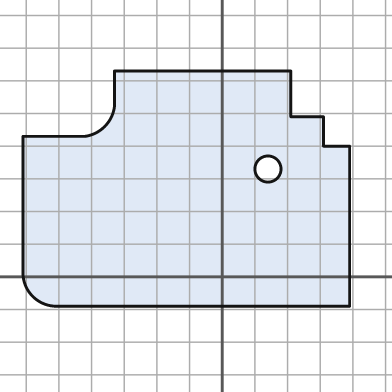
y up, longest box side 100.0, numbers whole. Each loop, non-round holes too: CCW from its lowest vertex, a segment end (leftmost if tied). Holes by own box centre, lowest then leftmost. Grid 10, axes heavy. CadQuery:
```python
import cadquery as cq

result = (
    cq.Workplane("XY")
    .moveTo(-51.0, -9.0)
    .lineTo(39.0, -9.0)
    .lineTo(39.0, 40.0)
    .lineTo(31.0, 40.0)
    .lineTo(31.0, 49.0)
    .lineTo(21.0, 49.0)
    .lineTo(21.0, 63.0)
    .lineTo(-33.0, 63.0)
    .lineTo(-33.0, 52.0)
    .threePointArc((-36.0, 46.0), (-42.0, 43.0))
    .lineTo(-61.0, 43.0)
    .lineTo(-61.0, 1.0)
    .threePointArc((-58.0, -6.0), (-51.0, -9.0))
    .close()
    .moveTo(14.0, 33.0)
    .circle(4.0)
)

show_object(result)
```